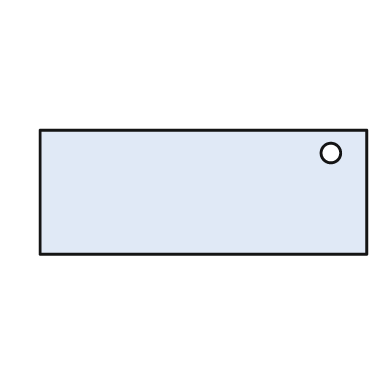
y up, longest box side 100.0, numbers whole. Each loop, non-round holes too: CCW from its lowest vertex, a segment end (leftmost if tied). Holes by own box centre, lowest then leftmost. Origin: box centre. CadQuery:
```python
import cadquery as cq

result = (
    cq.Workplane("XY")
    .moveTo(-50.0, -19.0)
    .lineTo(50.0, -19.0)
    .lineTo(50.0, 19.0)
    .lineTo(-50.0, 19.0)
    .close()
    .moveTo(39.0, 12.0)
    .circle(3.0)
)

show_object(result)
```